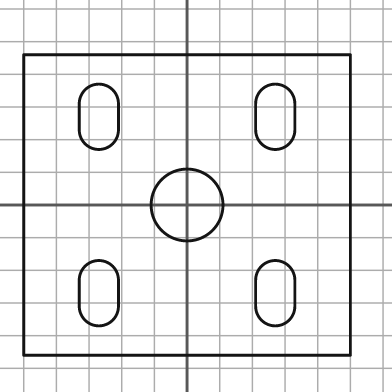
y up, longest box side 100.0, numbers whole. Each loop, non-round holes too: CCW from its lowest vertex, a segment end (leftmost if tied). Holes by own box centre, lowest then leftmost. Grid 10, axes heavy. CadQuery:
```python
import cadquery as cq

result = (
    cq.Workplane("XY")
    .moveTo(-50.0, -46.0)
    .lineTo(50.0, -46.0)
    .lineTo(50.0, 46.0)
    .lineTo(-50.0, 46.0)
    .close()
    .moveTo(-33.0, -31.0)
    .threePointArc((-27.0, -37.0), (-21.0, -31.0))
    .lineTo(-21.0, -23.0)
    .threePointArc((-27.0, -17.0), (-33.0, -23.0))
    .close()
    .moveTo(21.0, -31.0)
    .threePointArc((27.0, -37.0), (33.0, -31.0))
    .lineTo(33.0, -23.0)
    .threePointArc((27.0, -17.0), (21.0, -23.0))
    .close()
    .moveTo(0.0, 0.0)
    .circle(11.0)
    .moveTo(-33.0, 23.0)
    .threePointArc((-27.0, 17.0), (-21.0, 23.0))
    .lineTo(-21.0, 31.0)
    .threePointArc((-27.0, 37.0), (-33.0, 31.0))
    .close()
    .moveTo(21.0, 23.0)
    .threePointArc((27.0, 17.0), (33.0, 23.0))
    .lineTo(33.0, 31.0)
    .threePointArc((27.0, 37.0), (21.0, 31.0))
    .close()
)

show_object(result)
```